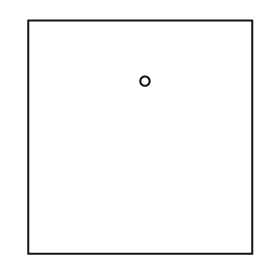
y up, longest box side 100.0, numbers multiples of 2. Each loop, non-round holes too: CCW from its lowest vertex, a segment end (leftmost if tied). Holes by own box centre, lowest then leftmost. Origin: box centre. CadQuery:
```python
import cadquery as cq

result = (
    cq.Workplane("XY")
    .moveTo(-48.0, -50.0)
    .lineTo(48.0, -50.0)
    .lineTo(48.0, 50.0)
    .lineTo(-48.0, 50.0)
    .close()
    .moveTo(2.0, 24.0)
    .circle(2.0)
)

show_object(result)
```